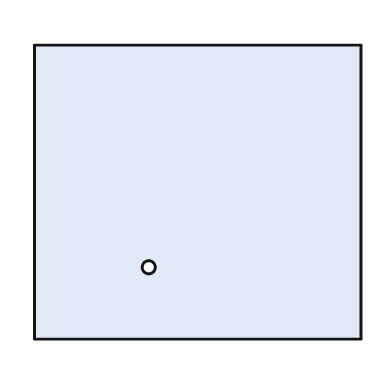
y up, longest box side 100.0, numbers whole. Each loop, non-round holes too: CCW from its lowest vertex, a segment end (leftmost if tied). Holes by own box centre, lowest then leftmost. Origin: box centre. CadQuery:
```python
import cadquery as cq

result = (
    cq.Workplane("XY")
    .moveTo(-50.0, -45.0)
    .lineTo(50.0, -45.0)
    .lineTo(50.0, 45.0)
    .lineTo(-50.0, 45.0)
    .close()
    .moveTo(-15.0, -23.0)
    .circle(2.0)
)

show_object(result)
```